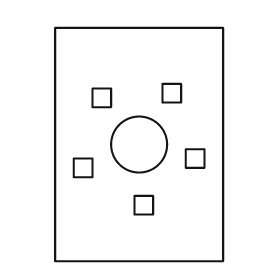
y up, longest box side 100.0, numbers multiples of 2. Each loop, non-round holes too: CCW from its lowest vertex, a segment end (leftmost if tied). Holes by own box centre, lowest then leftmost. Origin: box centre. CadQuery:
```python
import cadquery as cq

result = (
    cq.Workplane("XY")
    .moveTo(-36.0, -50.0)
    .lineTo(36.0, -50.0)
    .lineTo(36.0, 50.0)
    .lineTo(-36.0, 50.0)
    .close()
    .moveTo(-2.0, -30.0)
    .lineTo(6.0, -30.0)
    .lineTo(6.0, -22.0)
    .lineTo(-2.0, -22.0)
    .close()
    .moveTo(-28.0, -14.0)
    .lineTo(-20.0, -14.0)
    .lineTo(-20.0, -6.0)
    .lineTo(-28.0, -6.0)
    .close()
    .moveTo(20.0, -10.0)
    .lineTo(28.0, -10.0)
    .lineTo(28.0, -2.0)
    .lineTo(20.0, -2.0)
    .close()
    .moveTo(0.0, 0.0)
    .circle(12.0)
    .moveTo(-20.0, 16.0)
    .lineTo(-12.0, 16.0)
    .lineTo(-12.0, 24.0)
    .lineTo(-20.0, 24.0)
    .close()
    .moveTo(10.0, 18.0)
    .lineTo(18.0, 18.0)
    .lineTo(18.0, 26.0)
    .lineTo(10.0, 26.0)
    .close()
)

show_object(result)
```